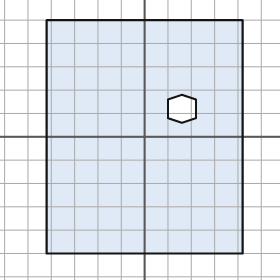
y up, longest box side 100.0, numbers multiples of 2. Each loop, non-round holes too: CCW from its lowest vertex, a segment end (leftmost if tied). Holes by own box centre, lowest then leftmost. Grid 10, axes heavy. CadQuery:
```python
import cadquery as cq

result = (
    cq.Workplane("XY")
    .moveTo(-42.0, -50.0)
    .lineTo(42.0, -50.0)
    .lineTo(42.0, 50.0)
    .lineTo(-42.0, 50.0)
    .close()
    .moveTo(16.0, 6.0)
    .lineTo(22.0, 8.0)
    .lineTo(22.0, 16.0)
    .lineTo(16.0, 18.0)
    .lineTo(10.0, 16.0)
    .lineTo(10.0, 8.0)
    .close()
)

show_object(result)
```